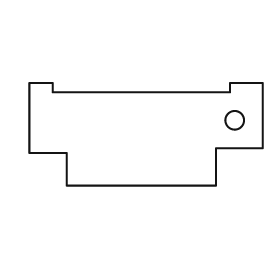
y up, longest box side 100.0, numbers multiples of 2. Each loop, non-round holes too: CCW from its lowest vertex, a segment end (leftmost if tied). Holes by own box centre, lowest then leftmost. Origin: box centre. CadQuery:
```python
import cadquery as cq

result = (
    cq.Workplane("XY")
    .moveTo(-34.0, -22.0)
    .lineTo(30.0, -22.0)
    .lineTo(30.0, -6.0)
    .lineTo(50.0, -6.0)
    .lineTo(50.0, 22.0)
    .lineTo(36.0, 22.0)
    .lineTo(36.0, 18.0)
    .lineTo(-40.0, 18.0)
    .lineTo(-40.0, 22.0)
    .lineTo(-50.0, 22.0)
    .lineTo(-50.0, -8.0)
    .lineTo(-34.0, -8.0)
    .close()
    .moveTo(38.0, 6.0)
    .circle(4.0)
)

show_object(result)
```